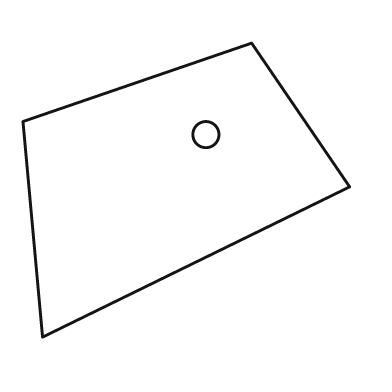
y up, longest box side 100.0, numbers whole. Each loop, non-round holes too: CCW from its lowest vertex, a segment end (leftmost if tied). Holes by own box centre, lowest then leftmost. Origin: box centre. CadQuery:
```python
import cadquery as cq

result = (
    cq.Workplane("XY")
    .moveTo(-44.0, -45.0)
    .lineTo(50.0, 1.0)
    .lineTo(20.0, 45.0)
    .lineTo(-50.0, 21.0)
    .close()
    .moveTo(6.0, 17.0)
    .circle(4.0)
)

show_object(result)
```